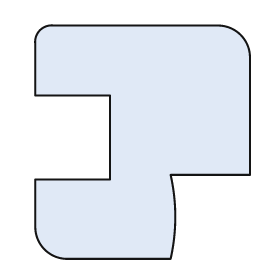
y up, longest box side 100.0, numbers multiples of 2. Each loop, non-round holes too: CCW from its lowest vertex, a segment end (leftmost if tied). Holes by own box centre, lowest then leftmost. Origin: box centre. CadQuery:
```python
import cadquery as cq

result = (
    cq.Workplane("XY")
    .moveTo(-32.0, -50.0)
    .lineTo(12.0, -50.0)
    .threePointArc((14.0, -32.0), (12.0, -14.0))
    .lineTo(46.0, -14.0)
    .lineTo(46.0, 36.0)
    .threePointArc((42.0, 46.0), (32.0, 50.0))
    .lineTo(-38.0, 50.0)
    .threePointArc((-44.0, 48.0), (-46.0, 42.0))
    .lineTo(-46.0, 20.0)
    .lineTo(-14.0, 20.0)
    .lineTo(-14.0, -16.0)
    .lineTo(-46.0, -16.0)
    .lineTo(-46.0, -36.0)
    .threePointArc((-42.0, -46.0), (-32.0, -50.0))
    .close()
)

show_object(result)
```